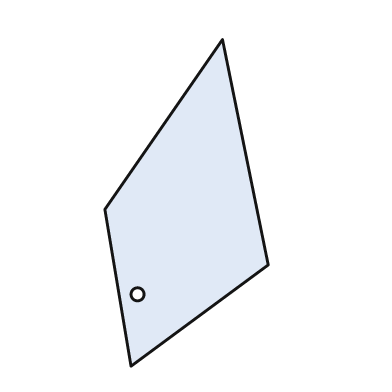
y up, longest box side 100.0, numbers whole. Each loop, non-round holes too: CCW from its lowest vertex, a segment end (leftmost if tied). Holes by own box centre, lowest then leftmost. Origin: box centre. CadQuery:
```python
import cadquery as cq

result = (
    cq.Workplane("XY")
    .moveTo(-17.0, -50.0)
    .lineTo(25.0, -19.0)
    .lineTo(11.0, 50.0)
    .lineTo(-25.0, -2.0)
    .close()
    .moveTo(-15.0, -28.0)
    .circle(2.0)
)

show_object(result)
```